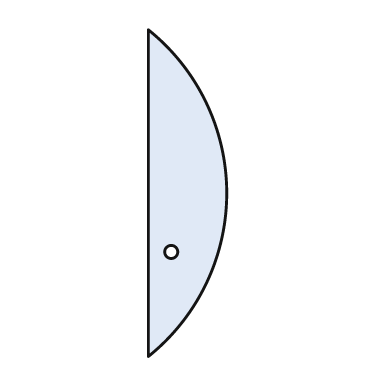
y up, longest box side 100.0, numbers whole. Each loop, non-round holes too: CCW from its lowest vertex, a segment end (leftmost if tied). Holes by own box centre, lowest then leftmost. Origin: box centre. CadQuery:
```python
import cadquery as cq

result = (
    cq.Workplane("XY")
    .moveTo(-12.0, -50.0)
    .threePointArc((12.0, 0.0), (-12.0, 50.0))
    .close()
    .moveTo(-5.0, -18.0)
    .circle(2.0)
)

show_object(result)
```